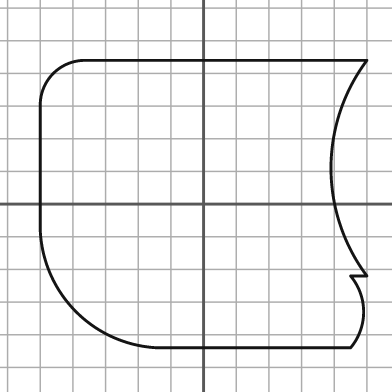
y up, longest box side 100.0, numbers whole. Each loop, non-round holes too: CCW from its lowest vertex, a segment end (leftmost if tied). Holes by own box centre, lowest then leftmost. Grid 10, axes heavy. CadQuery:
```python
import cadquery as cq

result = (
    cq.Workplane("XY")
    .moveTo(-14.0, -44.0)
    .lineTo(45.0, -44.0)
    .threePointArc((49.0, -33.0), (45.0, -22.0))
    .lineTo(50.0, -22.0)
    .threePointArc((39.0, 11.0), (50.0, 44.0))
    .lineTo(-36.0, 44.0)
    .threePointArc((-46.0, 40.0), (-50.0, 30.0))
    .lineTo(-50.0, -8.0)
    .threePointArc((-39.0, -33.0), (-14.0, -44.0))
    .close()
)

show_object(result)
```